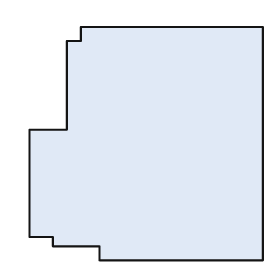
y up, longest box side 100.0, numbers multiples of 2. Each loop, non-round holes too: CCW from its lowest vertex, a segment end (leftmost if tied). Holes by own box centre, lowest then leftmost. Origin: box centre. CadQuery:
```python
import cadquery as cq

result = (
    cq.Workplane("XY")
    .moveTo(-20.0, -50.0)
    .lineTo(50.0, -50.0)
    .lineTo(50.0, 50.0)
    .lineTo(-28.0, 50.0)
    .lineTo(-28.0, 44.0)
    .lineTo(-34.0, 44.0)
    .lineTo(-34.0, 6.0)
    .lineTo(-50.0, 6.0)
    .lineTo(-50.0, -40.0)
    .lineTo(-40.0, -40.0)
    .lineTo(-40.0, -44.0)
    .lineTo(-20.0, -44.0)
    .close()
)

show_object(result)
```